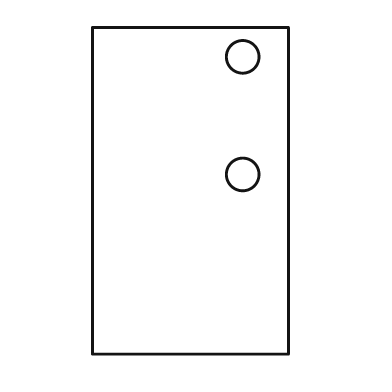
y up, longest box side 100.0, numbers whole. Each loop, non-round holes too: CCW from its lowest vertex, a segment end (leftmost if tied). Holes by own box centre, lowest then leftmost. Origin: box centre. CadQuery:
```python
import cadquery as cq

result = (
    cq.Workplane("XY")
    .moveTo(-30.0, -50.0)
    .lineTo(30.0, -50.0)
    .lineTo(30.0, 50.0)
    .lineTo(-30.0, 50.0)
    .close()
    .moveTo(16.0, 5.0)
    .circle(5.0)
    .moveTo(16.0, 41.0)
    .circle(5.0)
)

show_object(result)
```